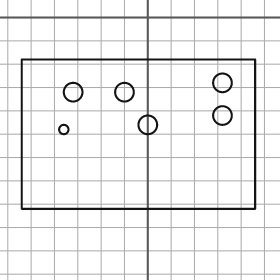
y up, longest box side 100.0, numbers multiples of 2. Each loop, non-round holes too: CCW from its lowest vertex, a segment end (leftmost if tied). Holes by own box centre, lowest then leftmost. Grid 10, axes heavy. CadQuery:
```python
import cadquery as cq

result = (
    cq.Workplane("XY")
    .moveTo(-54.0, -82.0)
    .lineTo(46.0, -82.0)
    .lineTo(46.0, -18.0)
    .lineTo(-54.0, -18.0)
    .close()
    .moveTo(-36.0, -48.0)
    .circle(2.0)
    .moveTo(0.0, -46.0)
    .circle(4.0)
    .moveTo(32.0, -42.0)
    .circle(4.0)
    .moveTo(-32.0, -32.0)
    .circle(4.0)
    .moveTo(-10.0, -32.0)
    .circle(4.0)
    .moveTo(32.0, -28.0)
    .circle(4.0)
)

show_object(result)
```